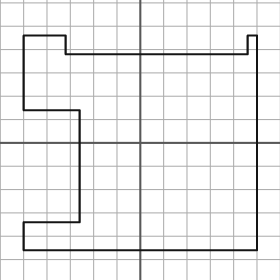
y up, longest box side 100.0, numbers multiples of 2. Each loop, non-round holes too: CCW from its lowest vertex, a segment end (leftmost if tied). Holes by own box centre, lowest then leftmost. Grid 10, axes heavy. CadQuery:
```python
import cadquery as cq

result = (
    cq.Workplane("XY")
    .moveTo(-50.0, -46.0)
    .lineTo(50.0, -46.0)
    .lineTo(50.0, 46.0)
    .lineTo(46.0, 46.0)
    .lineTo(46.0, 38.0)
    .lineTo(-32.0, 38.0)
    .lineTo(-32.0, 46.0)
    .lineTo(-50.0, 46.0)
    .lineTo(-50.0, 14.0)
    .lineTo(-26.0, 14.0)
    .lineTo(-26.0, -34.0)
    .lineTo(-50.0, -34.0)
    .close()
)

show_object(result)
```